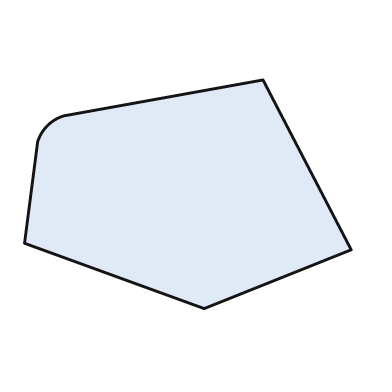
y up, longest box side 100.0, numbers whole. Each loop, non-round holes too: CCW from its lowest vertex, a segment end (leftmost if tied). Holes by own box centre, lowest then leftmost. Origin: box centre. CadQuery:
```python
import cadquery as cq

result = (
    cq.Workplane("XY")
    .moveTo(5.0, -35.0)
    .lineTo(50.0, -17.0)
    .lineTo(23.0, 35.0)
    .lineTo(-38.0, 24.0)
    .threePointArc((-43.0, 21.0), (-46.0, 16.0))
    .lineTo(-50.0, -15.0)
    .close()
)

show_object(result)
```